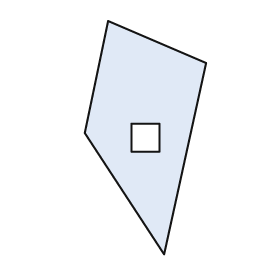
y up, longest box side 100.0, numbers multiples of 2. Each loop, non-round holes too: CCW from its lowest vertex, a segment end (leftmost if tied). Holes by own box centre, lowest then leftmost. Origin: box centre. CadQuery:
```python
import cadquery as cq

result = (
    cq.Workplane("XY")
    .moveTo(8.0, -50.0)
    .lineTo(26.0, 32.0)
    .lineTo(-16.0, 50.0)
    .lineTo(-26.0, 2.0)
    .close()
    .moveTo(-6.0, -6.0)
    .lineTo(6.0, -6.0)
    .lineTo(6.0, 6.0)
    .lineTo(-6.0, 6.0)
    .close()
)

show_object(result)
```